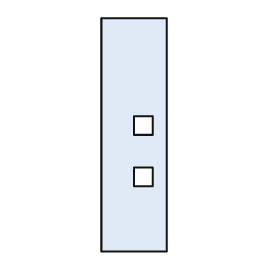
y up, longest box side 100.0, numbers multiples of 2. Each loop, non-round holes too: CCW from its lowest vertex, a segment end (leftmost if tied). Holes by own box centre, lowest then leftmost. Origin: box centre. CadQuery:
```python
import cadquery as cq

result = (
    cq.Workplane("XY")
    .moveTo(-14.0, -50.0)
    .lineTo(14.0, -50.0)
    .lineTo(14.0, 50.0)
    .lineTo(-14.0, 50.0)
    .close()
    .moveTo(0.0, -22.0)
    .lineTo(8.0, -22.0)
    .lineTo(8.0, -14.0)
    .lineTo(0.0, -14.0)
    .close()
    .moveTo(0.0, 0.0)
    .lineTo(8.0, 0.0)
    .lineTo(8.0, 8.0)
    .lineTo(0.0, 8.0)
    .close()
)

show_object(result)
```